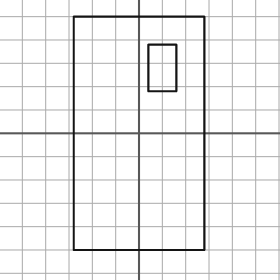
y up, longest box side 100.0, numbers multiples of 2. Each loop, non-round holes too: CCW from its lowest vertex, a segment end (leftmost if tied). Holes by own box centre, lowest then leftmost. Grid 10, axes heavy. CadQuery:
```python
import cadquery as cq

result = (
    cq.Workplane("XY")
    .moveTo(-28.0, -50.0)
    .lineTo(28.0, -50.0)
    .lineTo(28.0, 50.0)
    .lineTo(-28.0, 50.0)
    .close()
    .moveTo(4.0, 18.0)
    .lineTo(16.0, 18.0)
    .lineTo(16.0, 38.0)
    .lineTo(4.0, 38.0)
    .close()
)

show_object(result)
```